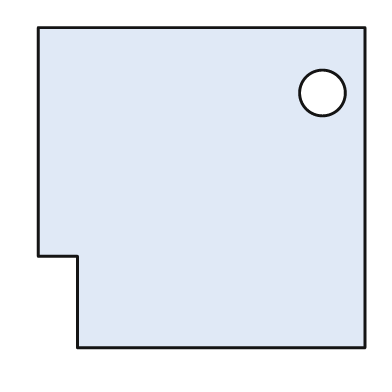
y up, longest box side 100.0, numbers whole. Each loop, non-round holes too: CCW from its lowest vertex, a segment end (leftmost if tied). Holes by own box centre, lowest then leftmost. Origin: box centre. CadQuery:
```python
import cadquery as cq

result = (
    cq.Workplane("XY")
    .moveTo(-38.0, -49.0)
    .lineTo(50.0, -49.0)
    .lineTo(50.0, 49.0)
    .lineTo(-50.0, 49.0)
    .lineTo(-50.0, -21.0)
    .lineTo(-38.0, -21.0)
    .close()
    .moveTo(37.0, 29.0)
    .circle(7.0)
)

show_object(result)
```